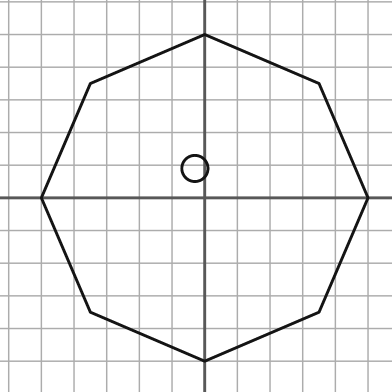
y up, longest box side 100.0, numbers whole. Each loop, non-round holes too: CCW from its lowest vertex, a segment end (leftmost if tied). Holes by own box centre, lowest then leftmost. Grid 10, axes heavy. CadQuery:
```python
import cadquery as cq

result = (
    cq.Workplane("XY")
    .moveTo(0.0, -50.0)
    .lineTo(35.0, -35.0)
    .lineTo(50.0, 0.0)
    .lineTo(35.0, 35.0)
    .lineTo(0.0, 50.0)
    .lineTo(-35.0, 35.0)
    .lineTo(-50.0, 0.0)
    .lineTo(-35.0, -35.0)
    .close()
    .moveTo(-3.0, 9.0)
    .circle(4.0)
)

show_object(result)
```